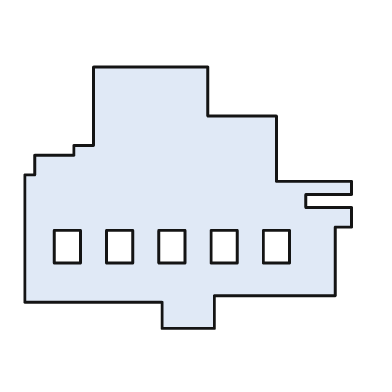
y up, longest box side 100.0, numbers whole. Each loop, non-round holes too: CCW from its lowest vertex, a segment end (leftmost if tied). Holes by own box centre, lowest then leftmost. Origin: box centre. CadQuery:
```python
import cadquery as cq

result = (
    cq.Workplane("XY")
    .moveTo(-8.0, -40.0)
    .lineTo(8.0, -40.0)
    .lineTo(8.0, -30.0)
    .lineTo(45.0, -30.0)
    .lineTo(45.0, -9.0)
    .lineTo(50.0, -9.0)
    .lineTo(50.0, -3.0)
    .lineTo(36.0, -3.0)
    .lineTo(36.0, 1.0)
    .lineTo(50.0, 1.0)
    .lineTo(50.0, 5.0)
    .lineTo(27.0, 5.0)
    .lineTo(27.0, 25.0)
    .lineTo(6.0, 25.0)
    .lineTo(6.0, 40.0)
    .lineTo(-29.0, 40.0)
    .lineTo(-29.0, 16.0)
    .lineTo(-35.0, 16.0)
    .lineTo(-35.0, 13.0)
    .lineTo(-47.0, 13.0)
    .lineTo(-47.0, 7.0)
    .lineTo(-50.0, 7.0)
    .lineTo(-50.0, -32.0)
    .lineTo(-8.0, -32.0)
    .close()
    .moveTo(-41.0, -20.0)
    .lineTo(-33.0, -20.0)
    .lineTo(-33.0, -10.0)
    .lineTo(-41.0, -10.0)
    .close()
    .moveTo(-25.0, -20.0)
    .lineTo(-17.0, -20.0)
    .lineTo(-17.0, -10.0)
    .lineTo(-25.0, -10.0)
    .close()
    .moveTo(-9.0, -20.0)
    .lineTo(-1.0, -20.0)
    .lineTo(-1.0, -10.0)
    .lineTo(-9.0, -10.0)
    .close()
    .moveTo(7.0, -20.0)
    .lineTo(15.0, -20.0)
    .lineTo(15.0, -10.0)
    .lineTo(7.0, -10.0)
    .close()
    .moveTo(23.0, -20.0)
    .lineTo(31.0, -20.0)
    .lineTo(31.0, -10.0)
    .lineTo(23.0, -10.0)
    .close()
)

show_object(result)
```